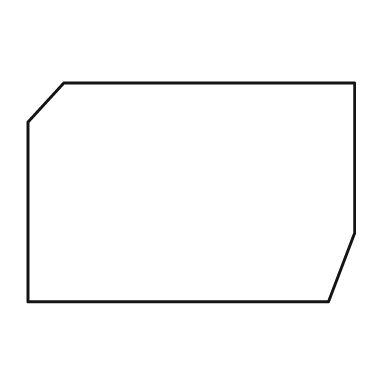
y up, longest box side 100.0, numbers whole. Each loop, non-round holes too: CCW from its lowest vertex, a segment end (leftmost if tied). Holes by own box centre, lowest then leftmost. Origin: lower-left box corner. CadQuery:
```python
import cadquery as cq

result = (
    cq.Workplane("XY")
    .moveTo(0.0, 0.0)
    .lineTo(92.0, 0.0)
    .lineTo(100.0, 21.0)
    .lineTo(100.0, 67.0)
    .lineTo(11.0, 67.0)
    .lineTo(0.0, 55.0)
    .close()
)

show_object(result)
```